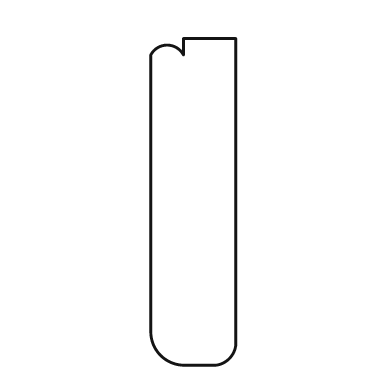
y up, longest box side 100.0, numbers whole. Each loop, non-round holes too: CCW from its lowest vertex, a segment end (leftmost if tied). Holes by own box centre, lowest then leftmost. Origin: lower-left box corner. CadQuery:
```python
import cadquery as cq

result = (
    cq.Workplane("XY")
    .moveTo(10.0, 0.0)
    .lineTo(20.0, 0.0)
    .threePointArc((24.0, 2.0), (26.0, 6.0))
    .lineTo(26.0, 100.0)
    .lineTo(10.0, 100.0)
    .lineTo(10.0, 95.0)
    .threePointArc((5.0, 98.0), (0.0, 95.0))
    .lineTo(0.0, 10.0)
    .threePointArc((3.0, 3.0), (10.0, 0.0))
    .close()
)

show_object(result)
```